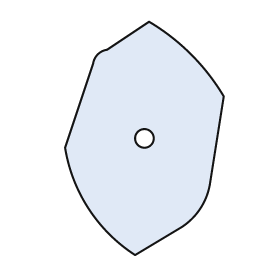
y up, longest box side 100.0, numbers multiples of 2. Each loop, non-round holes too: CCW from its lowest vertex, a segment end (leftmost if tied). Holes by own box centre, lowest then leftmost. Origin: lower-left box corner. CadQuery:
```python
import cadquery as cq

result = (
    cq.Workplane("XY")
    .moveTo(30.0, 0.0)
    .lineTo(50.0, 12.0)
    .threePointArc((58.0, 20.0), (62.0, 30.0))
    .lineTo(68.0, 68.0)
    .threePointArc((54.0, 86.0), (36.0, 100.0))
    .lineTo(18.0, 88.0)
    .threePointArc((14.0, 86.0), (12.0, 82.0))
    .lineTo(0.0, 46.0)
    .threePointArc((10.0, 20.0), (30.0, 0.0))
    .close()
    .moveTo(34.0, 50.0)
    .circle(4.0)
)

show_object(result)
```